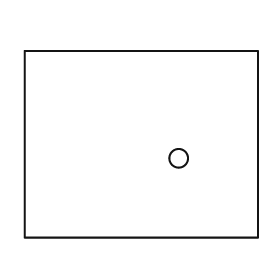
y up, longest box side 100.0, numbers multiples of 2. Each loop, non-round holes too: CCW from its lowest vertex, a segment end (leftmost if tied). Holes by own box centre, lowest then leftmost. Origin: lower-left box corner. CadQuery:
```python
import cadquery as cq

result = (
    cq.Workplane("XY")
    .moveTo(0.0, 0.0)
    .lineTo(100.0, 0.0)
    .lineTo(100.0, 80.0)
    .lineTo(0.0, 80.0)
    .close()
    .moveTo(66.0, 34.0)
    .circle(4.0)
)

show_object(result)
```